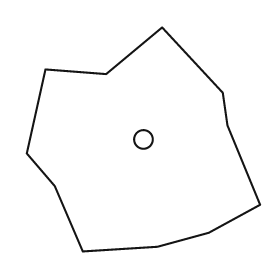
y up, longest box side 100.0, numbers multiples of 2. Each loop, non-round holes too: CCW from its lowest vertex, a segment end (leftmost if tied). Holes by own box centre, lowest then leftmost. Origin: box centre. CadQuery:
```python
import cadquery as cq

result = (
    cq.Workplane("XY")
    .moveTo(-26.0, -48.0)
    .lineTo(6.0, -46.0)
    .lineTo(28.0, -40.0)
    .lineTo(50.0, -28.0)
    .lineTo(36.0, 6.0)
    .lineTo(34.0, 20.0)
    .lineTo(8.0, 48.0)
    .lineTo(-16.0, 28.0)
    .lineTo(-42.0, 30.0)
    .lineTo(-50.0, -6.0)
    .lineTo(-38.0, -20.0)
    .close()
    .moveTo(0.0, 0.0)
    .circle(4.0)
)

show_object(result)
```